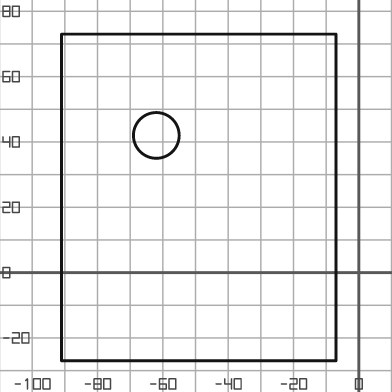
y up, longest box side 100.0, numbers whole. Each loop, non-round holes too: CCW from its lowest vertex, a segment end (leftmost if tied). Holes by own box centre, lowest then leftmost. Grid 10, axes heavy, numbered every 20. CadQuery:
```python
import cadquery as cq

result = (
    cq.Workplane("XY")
    .moveTo(-91.0, -27.0)
    .lineTo(-7.0, -27.0)
    .lineTo(-7.0, 73.0)
    .lineTo(-91.0, 73.0)
    .close()
    .moveTo(-62.0, 42.0)
    .circle(7.0)
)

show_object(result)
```